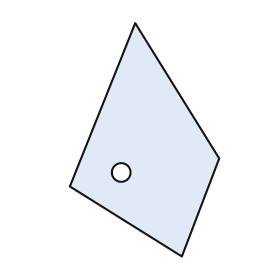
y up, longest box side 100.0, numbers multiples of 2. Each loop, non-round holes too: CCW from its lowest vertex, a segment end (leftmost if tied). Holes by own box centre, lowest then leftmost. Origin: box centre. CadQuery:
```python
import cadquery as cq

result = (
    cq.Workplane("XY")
    .moveTo(16.0, -50.0)
    .lineTo(32.0, -8.0)
    .lineTo(-4.0, 50.0)
    .lineTo(-32.0, -20.0)
    .close()
    .moveTo(-10.0, -14.0)
    .circle(4.0)
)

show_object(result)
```